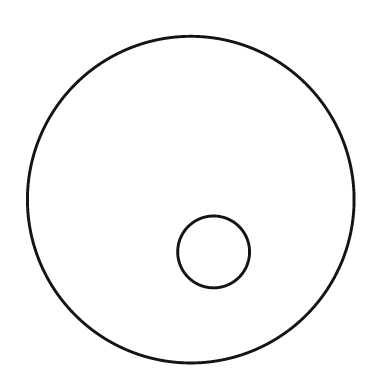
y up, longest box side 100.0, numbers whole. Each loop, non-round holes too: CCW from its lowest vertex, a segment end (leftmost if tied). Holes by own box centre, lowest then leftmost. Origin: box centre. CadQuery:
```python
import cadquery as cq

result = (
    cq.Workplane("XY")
    .moveTo(0.0, 0.0)
    .circle(50.0)
    .moveTo(7.0, -16.0)
    .circle(11.0)
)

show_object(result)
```